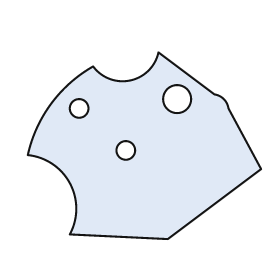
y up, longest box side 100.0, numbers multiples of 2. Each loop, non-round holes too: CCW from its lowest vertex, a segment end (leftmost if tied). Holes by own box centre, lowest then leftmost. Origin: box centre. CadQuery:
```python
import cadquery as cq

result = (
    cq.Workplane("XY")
    .moveTo(10.0, -40.0)
    .lineTo(50.0, -10.0)
    .lineTo(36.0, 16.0)
    .threePointArc((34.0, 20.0), (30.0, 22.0))
    .lineTo(6.0, 40.0)
    .threePointArc((-6.0, 28.0), (-22.0, 34.0))
    .threePointArc((-40.0, 18.0), (-50.0, -4.0))
    .threePointArc((-32.0, -16.0), (-32.0, -38.0))
    .close()
    .moveTo(-8.0, -2.0)
    .circle(4.0)
    .moveTo(-28.0, 16.0)
    .circle(4.0)
    .moveTo(14.0, 20.0)
    .circle(6.0)
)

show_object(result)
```